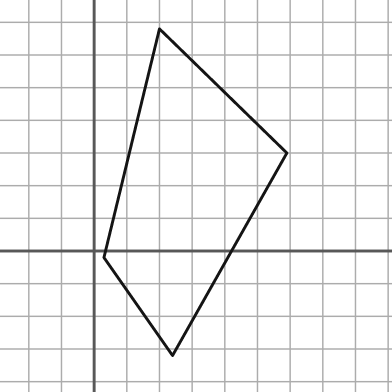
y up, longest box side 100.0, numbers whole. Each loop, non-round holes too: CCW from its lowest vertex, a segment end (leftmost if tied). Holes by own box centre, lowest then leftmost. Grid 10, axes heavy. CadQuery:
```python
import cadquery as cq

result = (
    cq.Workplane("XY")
    .moveTo(24.0, -32.0)
    .lineTo(59.0, 30.0)
    .lineTo(20.0, 68.0)
    .lineTo(3.0, -2.0)
    .close()
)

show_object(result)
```